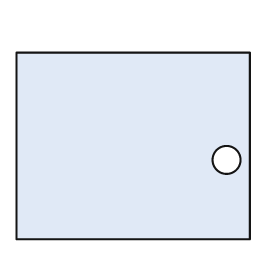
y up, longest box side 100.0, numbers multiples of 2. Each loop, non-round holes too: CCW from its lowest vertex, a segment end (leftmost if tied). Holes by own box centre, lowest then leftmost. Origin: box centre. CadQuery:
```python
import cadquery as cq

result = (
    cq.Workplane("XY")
    .moveTo(-50.0, -40.0)
    .lineTo(50.0, -40.0)
    .lineTo(50.0, 40.0)
    .lineTo(-50.0, 40.0)
    .close()
    .moveTo(40.0, -6.0)
    .circle(6.0)
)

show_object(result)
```